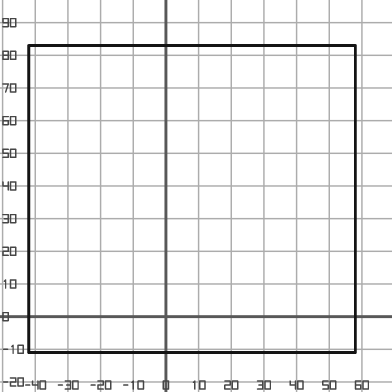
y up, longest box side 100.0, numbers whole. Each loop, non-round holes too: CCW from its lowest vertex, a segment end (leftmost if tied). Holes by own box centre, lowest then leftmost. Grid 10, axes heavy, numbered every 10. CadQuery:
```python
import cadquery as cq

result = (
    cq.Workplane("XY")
    .moveTo(-42.0, -11.0)
    .lineTo(58.0, -11.0)
    .lineTo(58.0, 83.0)
    .lineTo(-42.0, 83.0)
    .close()
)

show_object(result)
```